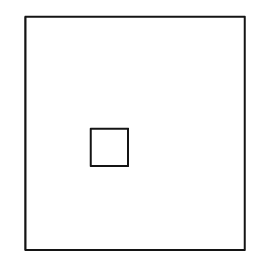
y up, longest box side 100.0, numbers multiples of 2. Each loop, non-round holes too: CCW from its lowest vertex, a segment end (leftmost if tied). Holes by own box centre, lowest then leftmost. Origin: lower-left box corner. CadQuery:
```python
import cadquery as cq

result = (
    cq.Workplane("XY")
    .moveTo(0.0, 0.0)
    .lineTo(94.0, 0.0)
    .lineTo(94.0, 100.0)
    .lineTo(0.0, 100.0)
    .close()
    .moveTo(28.0, 36.0)
    .lineTo(44.0, 36.0)
    .lineTo(44.0, 52.0)
    .lineTo(28.0, 52.0)
    .close()
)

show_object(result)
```